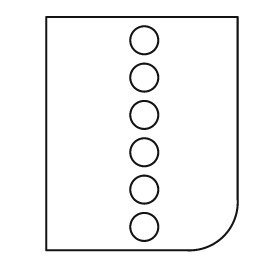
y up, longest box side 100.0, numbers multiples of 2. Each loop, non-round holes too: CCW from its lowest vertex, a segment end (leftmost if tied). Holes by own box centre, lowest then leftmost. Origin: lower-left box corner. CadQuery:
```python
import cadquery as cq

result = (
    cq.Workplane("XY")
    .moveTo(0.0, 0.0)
    .lineTo(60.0, 0.0)
    .threePointArc((76.0, 6.0), (82.0, 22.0))
    .lineTo(82.0, 100.0)
    .lineTo(0.0, 100.0)
    .close()
    .moveTo(42.0, 10.0)
    .circle(6.0)
    .moveTo(42.0, 26.0)
    .circle(6.0)
    .moveTo(42.0, 42.0)
    .circle(6.0)
    .moveTo(42.0, 58.0)
    .circle(6.0)
    .moveTo(42.0, 74.0)
    .circle(6.0)
    .moveTo(42.0, 90.0)
    .circle(6.0)
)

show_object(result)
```